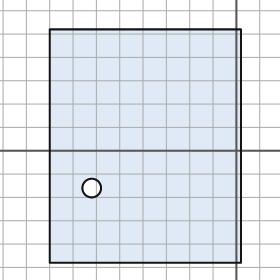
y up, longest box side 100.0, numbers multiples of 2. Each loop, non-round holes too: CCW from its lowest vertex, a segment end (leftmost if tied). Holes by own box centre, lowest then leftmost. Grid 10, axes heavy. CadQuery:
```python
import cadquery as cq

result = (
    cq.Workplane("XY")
    .moveTo(-80.0, -48.0)
    .lineTo(2.0, -48.0)
    .lineTo(2.0, 52.0)
    .lineTo(-80.0, 52.0)
    .close()
    .moveTo(-62.0, -16.0)
    .circle(4.0)
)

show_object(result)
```